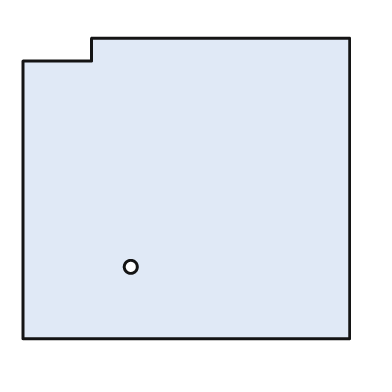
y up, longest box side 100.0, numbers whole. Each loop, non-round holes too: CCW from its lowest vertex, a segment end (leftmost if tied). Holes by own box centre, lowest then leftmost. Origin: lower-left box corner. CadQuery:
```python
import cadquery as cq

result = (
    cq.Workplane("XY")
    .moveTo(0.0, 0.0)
    .lineTo(100.0, 0.0)
    .lineTo(100.0, 92.0)
    .lineTo(21.0, 92.0)
    .lineTo(21.0, 85.0)
    .lineTo(0.0, 85.0)
    .close()
    .moveTo(33.0, 22.0)
    .circle(2.0)
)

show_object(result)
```